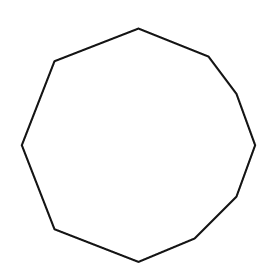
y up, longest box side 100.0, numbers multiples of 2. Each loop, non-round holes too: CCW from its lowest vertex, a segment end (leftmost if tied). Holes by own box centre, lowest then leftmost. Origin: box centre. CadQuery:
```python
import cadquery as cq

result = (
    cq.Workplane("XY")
    .moveTo(0.0, -50.0)
    .lineTo(24.0, -40.0)
    .lineTo(42.0, -22.0)
    .lineTo(50.0, 0.0)
    .lineTo(42.0, 22.0)
    .lineTo(30.0, 38.0)
    .lineTo(0.0, 50.0)
    .lineTo(-36.0, 36.0)
    .lineTo(-50.0, 0.0)
    .lineTo(-36.0, -36.0)
    .close()
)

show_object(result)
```